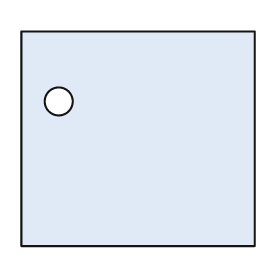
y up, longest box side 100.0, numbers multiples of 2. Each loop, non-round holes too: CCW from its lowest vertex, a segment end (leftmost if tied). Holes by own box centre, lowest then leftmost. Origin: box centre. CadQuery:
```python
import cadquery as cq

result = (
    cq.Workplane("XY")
    .moveTo(-50.0, -46.0)
    .lineTo(50.0, -46.0)
    .lineTo(50.0, 46.0)
    .lineTo(-50.0, 46.0)
    .close()
    .moveTo(-34.0, 16.0)
    .circle(6.0)
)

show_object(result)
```